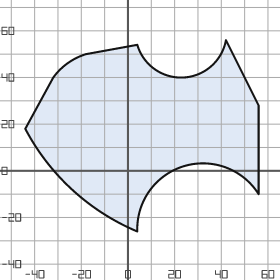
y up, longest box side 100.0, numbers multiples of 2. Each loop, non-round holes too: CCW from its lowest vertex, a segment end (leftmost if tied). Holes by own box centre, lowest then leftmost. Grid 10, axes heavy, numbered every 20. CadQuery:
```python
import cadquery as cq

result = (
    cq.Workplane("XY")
    .moveTo(4.0, -26.0)
    .threePointArc((24.0, 2.0), (56.0, -10.0))
    .lineTo(56.0, 28.0)
    .lineTo(42.0, 56.0)
    .threePointArc((24.0, 40.0), (4.0, 54.0))
    .lineTo(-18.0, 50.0)
    .threePointArc((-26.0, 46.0), (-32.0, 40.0))
    .lineTo(-44.0, 18.0)
    .threePointArc((-24.0, -8.0), (4.0, -26.0))
    .close()
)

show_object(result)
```